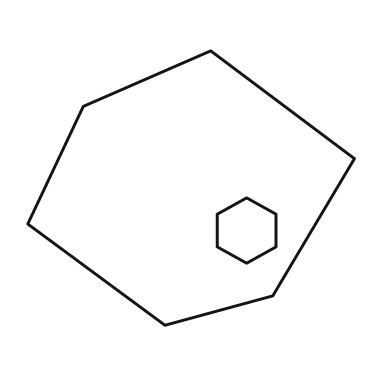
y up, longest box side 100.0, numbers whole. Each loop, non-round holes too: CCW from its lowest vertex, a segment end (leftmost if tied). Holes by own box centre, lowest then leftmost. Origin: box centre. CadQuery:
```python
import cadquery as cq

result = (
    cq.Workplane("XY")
    .moveTo(-8.0, -42.0)
    .lineTo(25.0, -33.0)
    .lineTo(50.0, 9.0)
    .lineTo(6.0, 42.0)
    .lineTo(-33.0, 25.0)
    .lineTo(-50.0, -11.0)
    .close()
    .moveTo(17.0, -23.0)
    .lineTo(26.0, -18.0)
    .lineTo(26.0, -8.0)
    .lineTo(17.0, -3.0)
    .lineTo(8.0, -8.0)
    .lineTo(8.0, -18.0)
    .close()
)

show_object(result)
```